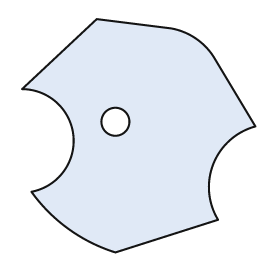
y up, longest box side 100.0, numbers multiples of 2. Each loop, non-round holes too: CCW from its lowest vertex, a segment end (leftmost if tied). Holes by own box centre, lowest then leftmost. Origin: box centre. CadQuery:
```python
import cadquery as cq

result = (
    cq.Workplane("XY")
    .moveTo(-10.0, -50.0)
    .lineTo(34.0, -36.0)
    .threePointArc((32.0, -12.0), (50.0, 4.0))
    .lineTo(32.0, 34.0)
    .threePointArc((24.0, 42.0), (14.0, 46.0))
    .lineTo(-18.0, 50.0)
    .lineTo(-50.0, 20.0)
    .threePointArc((-28.0, 0.0), (-46.0, -24.0))
    .threePointArc((-30.0, -40.0), (-10.0, -50.0))
    .close()
    .moveTo(-10.0, 6.0)
    .circle(6.0)
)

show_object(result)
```